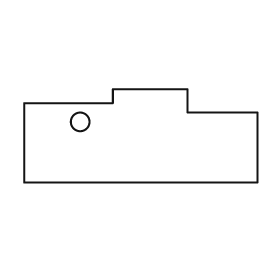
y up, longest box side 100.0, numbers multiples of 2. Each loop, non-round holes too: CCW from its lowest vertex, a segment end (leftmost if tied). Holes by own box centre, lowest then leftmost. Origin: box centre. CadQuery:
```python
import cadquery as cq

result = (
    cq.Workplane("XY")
    .moveTo(-50.0, -20.0)
    .lineTo(50.0, -20.0)
    .lineTo(50.0, 10.0)
    .lineTo(20.0, 10.0)
    .lineTo(20.0, 20.0)
    .lineTo(-12.0, 20.0)
    .lineTo(-12.0, 14.0)
    .lineTo(-50.0, 14.0)
    .close()
    .moveTo(-26.0, 6.0)
    .circle(4.0)
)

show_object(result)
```